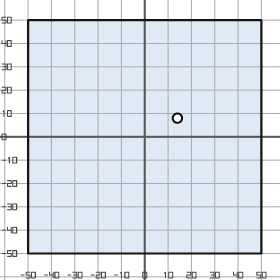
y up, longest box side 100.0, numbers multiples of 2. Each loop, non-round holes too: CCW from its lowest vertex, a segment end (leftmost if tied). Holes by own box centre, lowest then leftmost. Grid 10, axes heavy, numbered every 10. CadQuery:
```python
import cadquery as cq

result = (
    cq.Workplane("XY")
    .moveTo(-50.0, -50.0)
    .lineTo(50.0, -50.0)
    .lineTo(50.0, 50.0)
    .lineTo(-50.0, 50.0)
    .close()
    .moveTo(14.0, 8.0)
    .circle(2.0)
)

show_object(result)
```